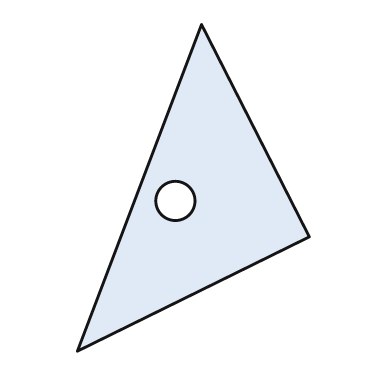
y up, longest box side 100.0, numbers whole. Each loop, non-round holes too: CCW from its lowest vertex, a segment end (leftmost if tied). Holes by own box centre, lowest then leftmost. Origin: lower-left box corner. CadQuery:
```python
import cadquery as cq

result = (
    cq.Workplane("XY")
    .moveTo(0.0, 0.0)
    .lineTo(71.0, 35.0)
    .lineTo(38.0, 100.0)
    .close()
    .moveTo(30.0, 46.0)
    .circle(6.0)
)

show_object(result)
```